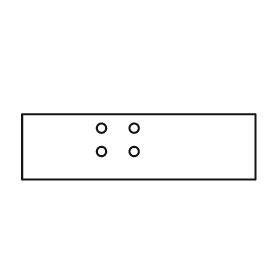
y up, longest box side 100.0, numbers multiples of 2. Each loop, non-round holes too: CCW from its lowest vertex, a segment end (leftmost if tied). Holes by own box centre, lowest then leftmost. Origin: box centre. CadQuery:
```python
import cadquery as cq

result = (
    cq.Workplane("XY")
    .moveTo(-50.0, -14.0)
    .lineTo(50.0, -14.0)
    .lineTo(50.0, 14.0)
    .lineTo(-50.0, 14.0)
    .close()
    .moveTo(-16.0, -2.0)
    .circle(2.0)
    .moveTo(-2.0, -2.0)
    .circle(2.0)
    .moveTo(-16.0, 8.0)
    .circle(2.0)
    .moveTo(-2.0, 8.0)
    .circle(2.0)
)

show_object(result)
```